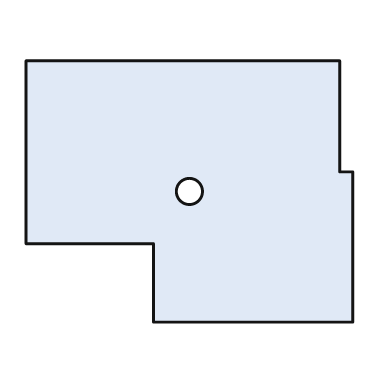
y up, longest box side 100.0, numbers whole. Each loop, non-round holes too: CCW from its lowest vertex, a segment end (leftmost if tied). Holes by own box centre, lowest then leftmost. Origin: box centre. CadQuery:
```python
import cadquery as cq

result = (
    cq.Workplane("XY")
    .moveTo(-11.0, -40.0)
    .lineTo(50.0, -40.0)
    .lineTo(50.0, 6.0)
    .lineTo(46.0, 6.0)
    .lineTo(46.0, 40.0)
    .lineTo(-50.0, 40.0)
    .lineTo(-50.0, -16.0)
    .lineTo(-11.0, -16.0)
    .close()
    .moveTo(0.0, 0.0)
    .circle(4.0)
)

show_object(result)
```